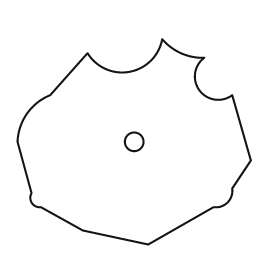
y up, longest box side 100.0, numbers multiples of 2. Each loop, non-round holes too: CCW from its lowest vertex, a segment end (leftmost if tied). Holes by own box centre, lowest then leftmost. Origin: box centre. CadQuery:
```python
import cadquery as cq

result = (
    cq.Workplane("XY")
    .moveTo(6.0, -44.0)
    .lineTo(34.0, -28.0)
    .threePointArc((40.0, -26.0), (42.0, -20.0))
    .lineTo(50.0, -8.0)
    .lineTo(42.0, 20.0)
    .threePointArc((28.0, 22.0), (30.0, 36.0))
    .threePointArc((20.0, 38.0), (12.0, 44.0))
    .threePointArc((-2.0, 30.0), (-20.0, 38.0))
    .lineTo(-36.0, 20.0)
    .threePointArc((-46.0, 12.0), (-50.0, 0.0))
    .lineTo(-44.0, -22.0)
    .threePointArc((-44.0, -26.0), (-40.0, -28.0))
    .lineTo(-22.0, -38.0)
    .close()
    .moveTo(0.0, 0.0)
    .circle(4.0)
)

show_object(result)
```